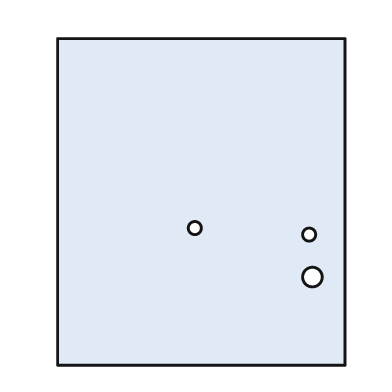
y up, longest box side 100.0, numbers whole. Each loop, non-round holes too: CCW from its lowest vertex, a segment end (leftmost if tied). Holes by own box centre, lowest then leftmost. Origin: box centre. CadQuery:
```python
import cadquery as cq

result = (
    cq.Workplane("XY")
    .moveTo(-44.0, -50.0)
    .lineTo(44.0, -50.0)
    .lineTo(44.0, 50.0)
    .lineTo(-44.0, 50.0)
    .close()
    .moveTo(34.0, -23.0)
    .circle(3.0)
    .moveTo(33.0, -10.0)
    .circle(2.0)
    .moveTo(-2.0, -8.0)
    .circle(2.0)
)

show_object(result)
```